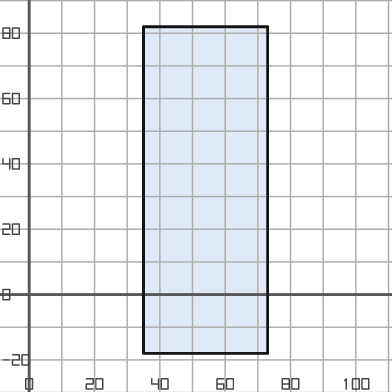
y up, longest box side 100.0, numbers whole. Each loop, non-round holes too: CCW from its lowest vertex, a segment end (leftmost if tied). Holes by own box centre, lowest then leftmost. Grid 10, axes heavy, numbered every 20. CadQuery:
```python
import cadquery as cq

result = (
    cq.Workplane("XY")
    .moveTo(35.0, -18.0)
    .lineTo(73.0, -18.0)
    .lineTo(73.0, 82.0)
    .lineTo(35.0, 82.0)
    .close()
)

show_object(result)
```